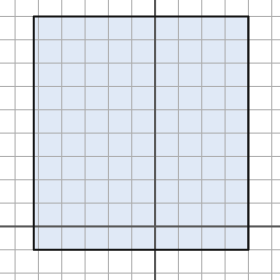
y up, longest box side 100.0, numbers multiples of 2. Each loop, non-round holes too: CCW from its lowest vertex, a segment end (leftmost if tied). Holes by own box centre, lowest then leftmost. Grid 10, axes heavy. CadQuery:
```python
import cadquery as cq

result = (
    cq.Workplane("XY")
    .moveTo(-52.0, -10.0)
    .lineTo(40.0, -10.0)
    .lineTo(40.0, 90.0)
    .lineTo(-52.0, 90.0)
    .close()
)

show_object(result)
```